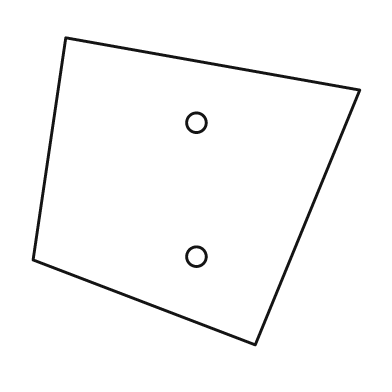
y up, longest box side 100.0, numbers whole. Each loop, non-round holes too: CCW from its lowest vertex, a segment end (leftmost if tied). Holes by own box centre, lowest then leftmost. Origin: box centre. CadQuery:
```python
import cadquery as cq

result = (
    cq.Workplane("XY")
    .moveTo(18.0, -47.0)
    .lineTo(50.0, 31.0)
    .lineTo(-40.0, 47.0)
    .lineTo(-50.0, -21.0)
    .close()
    .moveTo(0.0, -20.0)
    .circle(3.0)
    .moveTo(0.0, 21.0)
    .circle(3.0)
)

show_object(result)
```